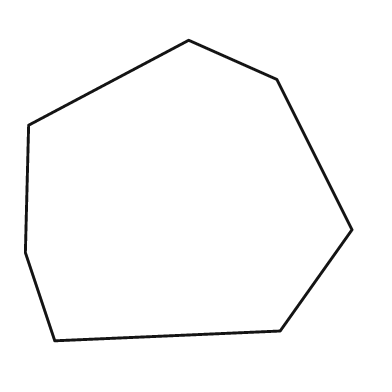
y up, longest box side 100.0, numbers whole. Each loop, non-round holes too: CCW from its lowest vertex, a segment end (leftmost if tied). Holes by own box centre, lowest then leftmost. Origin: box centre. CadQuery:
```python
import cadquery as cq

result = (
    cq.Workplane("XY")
    .moveTo(-41.0, -46.0)
    .lineTo(28.0, -43.0)
    .lineTo(50.0, -12.0)
    .lineTo(27.0, 34.0)
    .lineTo(0.0, 46.0)
    .lineTo(-49.0, 20.0)
    .lineTo(-50.0, -19.0)
    .close()
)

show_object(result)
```